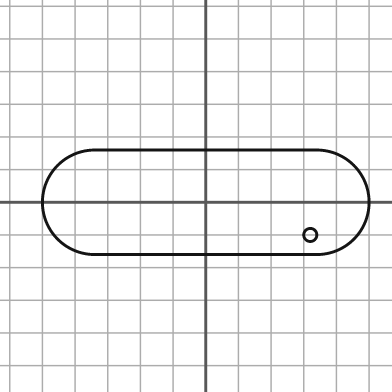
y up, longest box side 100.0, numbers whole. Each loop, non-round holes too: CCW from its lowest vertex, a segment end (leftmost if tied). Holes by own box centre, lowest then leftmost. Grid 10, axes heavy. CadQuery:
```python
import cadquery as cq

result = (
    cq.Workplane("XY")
    .moveTo(-34.0, -16.0)
    .lineTo(34.0, -16.0)
    .threePointArc((50.0, 0.0), (34.0, 16.0))
    .lineTo(-34.0, 16.0)
    .threePointArc((-50.0, 0.0), (-34.0, -16.0))
    .close()
    .moveTo(32.0, -10.0)
    .circle(2.0)
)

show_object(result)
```